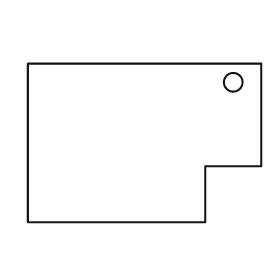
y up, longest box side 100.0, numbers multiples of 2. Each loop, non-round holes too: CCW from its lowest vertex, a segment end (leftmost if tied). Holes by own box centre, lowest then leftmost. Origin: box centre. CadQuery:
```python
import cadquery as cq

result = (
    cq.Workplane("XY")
    .moveTo(-50.0, -34.0)
    .lineTo(26.0, -34.0)
    .lineTo(26.0, -10.0)
    .lineTo(50.0, -10.0)
    .lineTo(50.0, 34.0)
    .lineTo(-50.0, 34.0)
    .close()
    .moveTo(38.0, 26.0)
    .circle(4.0)
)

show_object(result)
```